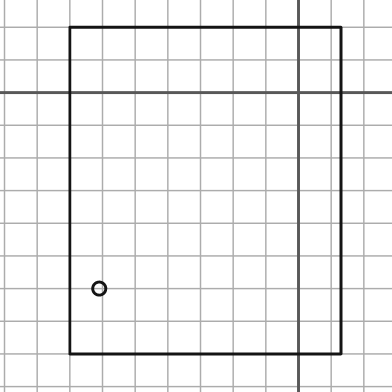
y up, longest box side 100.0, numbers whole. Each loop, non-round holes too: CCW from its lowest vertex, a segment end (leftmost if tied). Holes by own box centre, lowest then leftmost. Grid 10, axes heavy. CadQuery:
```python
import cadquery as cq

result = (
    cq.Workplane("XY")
    .moveTo(-70.0, -80.0)
    .lineTo(13.0, -80.0)
    .lineTo(13.0, 20.0)
    .lineTo(-70.0, 20.0)
    .close()
    .moveTo(-61.0, -60.0)
    .circle(2.0)
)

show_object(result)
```